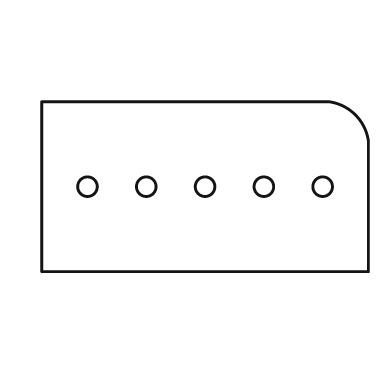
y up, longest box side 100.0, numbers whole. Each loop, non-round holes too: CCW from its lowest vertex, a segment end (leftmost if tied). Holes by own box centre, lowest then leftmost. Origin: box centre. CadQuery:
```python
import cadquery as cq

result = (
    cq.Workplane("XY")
    .moveTo(-50.0, -26.0)
    .lineTo(50.0, -26.0)
    .lineTo(50.0, 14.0)
    .threePointArc((46.0, 22.0), (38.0, 26.0))
    .lineTo(-50.0, 26.0)
    .close()
    .moveTo(-36.0, 0.0)
    .circle(3.0)
    .moveTo(-18.0, 0.0)
    .circle(3.0)
    .moveTo(0.0, 0.0)
    .circle(3.0)
    .moveTo(18.0, 0.0)
    .circle(3.0)
    .moveTo(36.0, 0.0)
    .circle(3.0)
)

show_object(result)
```